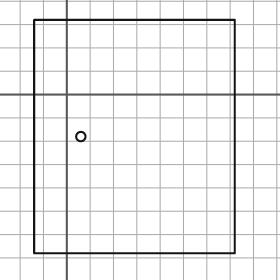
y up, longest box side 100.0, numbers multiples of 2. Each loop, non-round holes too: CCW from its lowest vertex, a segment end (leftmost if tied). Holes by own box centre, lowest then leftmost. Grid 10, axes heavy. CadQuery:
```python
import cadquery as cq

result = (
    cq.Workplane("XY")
    .moveTo(-14.0, -68.0)
    .lineTo(72.0, -68.0)
    .lineTo(72.0, 32.0)
    .lineTo(-14.0, 32.0)
    .close()
    .moveTo(6.0, -18.0)
    .circle(2.0)
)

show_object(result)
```